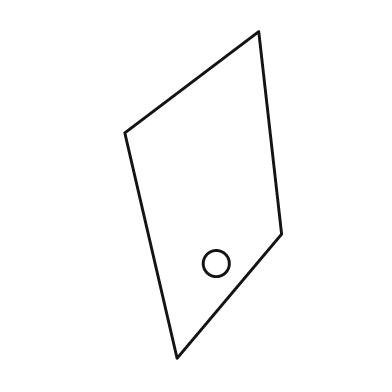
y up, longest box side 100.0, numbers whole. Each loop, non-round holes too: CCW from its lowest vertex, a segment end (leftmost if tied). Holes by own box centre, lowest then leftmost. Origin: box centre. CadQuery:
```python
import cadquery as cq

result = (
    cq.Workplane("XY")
    .moveTo(-8.0, -50.0)
    .lineTo(24.0, -12.0)
    .lineTo(17.0, 50.0)
    .lineTo(-24.0, 19.0)
    .close()
    .moveTo(4.0, -21.0)
    .circle(4.0)
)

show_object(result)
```